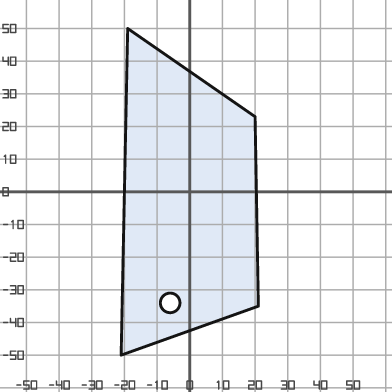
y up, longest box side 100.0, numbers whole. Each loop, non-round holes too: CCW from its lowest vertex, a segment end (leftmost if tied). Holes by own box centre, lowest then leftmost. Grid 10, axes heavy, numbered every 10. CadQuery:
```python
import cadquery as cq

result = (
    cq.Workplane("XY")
    .moveTo(-21.0, -50.0)
    .lineTo(21.0, -35.0)
    .lineTo(20.0, 23.0)
    .lineTo(-19.0, 50.0)
    .close()
    .moveTo(-6.0, -34.0)
    .circle(3.0)
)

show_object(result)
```